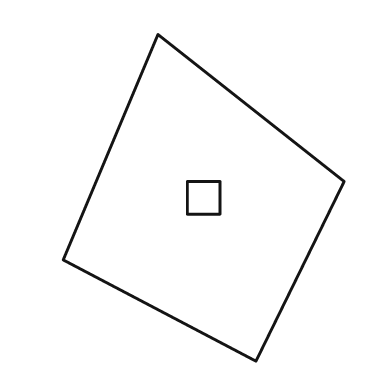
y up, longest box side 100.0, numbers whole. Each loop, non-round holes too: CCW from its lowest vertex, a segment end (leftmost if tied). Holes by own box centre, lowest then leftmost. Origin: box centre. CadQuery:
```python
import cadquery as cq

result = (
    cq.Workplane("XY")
    .moveTo(16.0, -50.0)
    .lineTo(43.0, 5.0)
    .lineTo(-14.0, 50.0)
    .lineTo(-43.0, -19.0)
    .close()
    .moveTo(-5.0, -5.0)
    .lineTo(5.0, -5.0)
    .lineTo(5.0, 5.0)
    .lineTo(-5.0, 5.0)
    .close()
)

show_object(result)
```